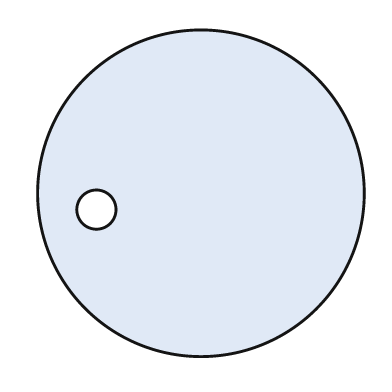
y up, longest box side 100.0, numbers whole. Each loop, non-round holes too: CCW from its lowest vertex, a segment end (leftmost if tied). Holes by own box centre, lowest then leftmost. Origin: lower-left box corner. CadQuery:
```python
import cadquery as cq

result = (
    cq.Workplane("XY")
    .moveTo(50.0, 50.0)
    .circle(50.0)
    .moveTo(18.0, 45.0)
    .circle(6.0)
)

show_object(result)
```